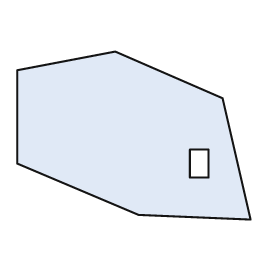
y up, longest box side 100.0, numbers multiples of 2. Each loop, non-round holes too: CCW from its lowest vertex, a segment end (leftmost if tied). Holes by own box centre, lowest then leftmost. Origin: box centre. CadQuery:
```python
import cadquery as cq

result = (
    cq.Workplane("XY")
    .moveTo(50.0, -36.0)
    .lineTo(38.0, 16.0)
    .lineTo(-8.0, 36.0)
    .lineTo(-50.0, 28.0)
    .lineTo(-50.0, -12.0)
    .lineTo(2.0, -34.0)
    .close()
    .moveTo(24.0, -18.0)
    .lineTo(32.0, -18.0)
    .lineTo(32.0, -6.0)
    .lineTo(24.0, -6.0)
    .close()
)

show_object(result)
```